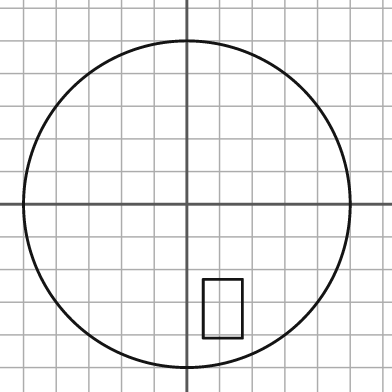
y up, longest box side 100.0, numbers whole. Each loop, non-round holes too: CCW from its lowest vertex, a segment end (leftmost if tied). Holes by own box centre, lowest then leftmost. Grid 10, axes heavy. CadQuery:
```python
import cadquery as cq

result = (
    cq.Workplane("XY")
    .moveTo(0.0, 0.0)
    .circle(50.0)
    .moveTo(5.0, -41.0)
    .lineTo(17.0, -41.0)
    .lineTo(17.0, -23.0)
    .lineTo(5.0, -23.0)
    .close()
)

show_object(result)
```